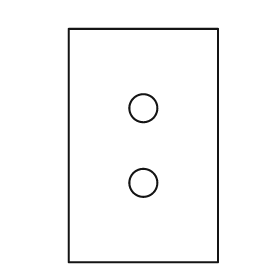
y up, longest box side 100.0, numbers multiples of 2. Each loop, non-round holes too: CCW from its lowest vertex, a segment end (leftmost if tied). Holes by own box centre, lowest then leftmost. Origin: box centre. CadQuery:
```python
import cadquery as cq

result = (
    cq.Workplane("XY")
    .moveTo(-32.0, -50.0)
    .lineTo(32.0, -50.0)
    .lineTo(32.0, 50.0)
    .lineTo(-32.0, 50.0)
    .close()
    .moveTo(0.0, -16.0)
    .circle(6.0)
    .moveTo(0.0, 16.0)
    .circle(6.0)
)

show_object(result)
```